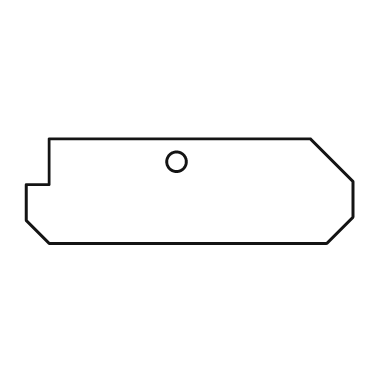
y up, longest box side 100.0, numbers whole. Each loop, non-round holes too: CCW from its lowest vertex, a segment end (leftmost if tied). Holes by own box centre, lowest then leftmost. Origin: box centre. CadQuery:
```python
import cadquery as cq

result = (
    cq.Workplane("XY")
    .moveTo(-43.0, -16.0)
    .lineTo(42.0, -16.0)
    .lineTo(50.0, -8.0)
    .lineTo(50.0, 3.0)
    .lineTo(37.0, 16.0)
    .lineTo(-43.0, 16.0)
    .lineTo(-43.0, 2.0)
    .lineTo(-50.0, 2.0)
    .lineTo(-50.0, -9.0)
    .close()
    .moveTo(-4.0, 9.0)
    .circle(3.0)
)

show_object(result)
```